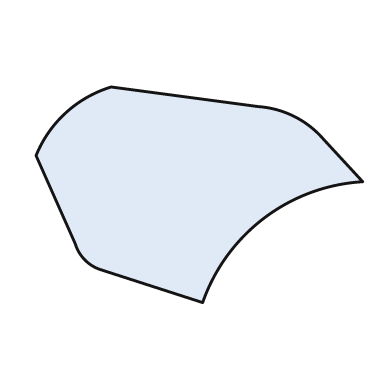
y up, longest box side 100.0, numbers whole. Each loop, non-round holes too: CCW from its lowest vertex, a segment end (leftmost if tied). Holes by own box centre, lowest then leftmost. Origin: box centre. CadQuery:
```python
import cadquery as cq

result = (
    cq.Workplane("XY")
    .moveTo(1.0, -33.0)
    .threePointArc((20.0, -7.0), (50.0, 4.0))
    .lineTo(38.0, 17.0)
    .threePointArc((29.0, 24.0), (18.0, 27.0))
    .lineTo(-27.0, 33.0)
    .threePointArc((-41.0, 25.0), (-50.0, 12.0))
    .lineTo(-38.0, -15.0)
    .threePointArc((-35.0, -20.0), (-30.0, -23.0))
    .close()
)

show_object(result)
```